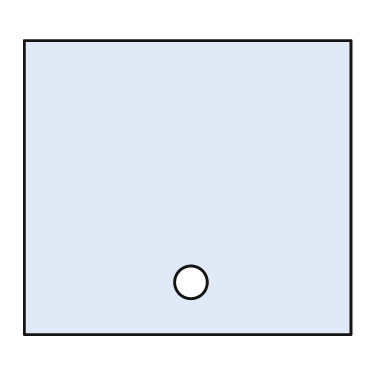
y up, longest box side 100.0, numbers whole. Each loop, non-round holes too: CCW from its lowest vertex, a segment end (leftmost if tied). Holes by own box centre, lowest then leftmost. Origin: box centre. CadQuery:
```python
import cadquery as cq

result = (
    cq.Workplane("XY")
    .moveTo(-50.0, -45.0)
    .lineTo(50.0, -45.0)
    .lineTo(50.0, 45.0)
    .lineTo(-50.0, 45.0)
    .close()
    .moveTo(1.0, -29.0)
    .circle(5.0)
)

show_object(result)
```